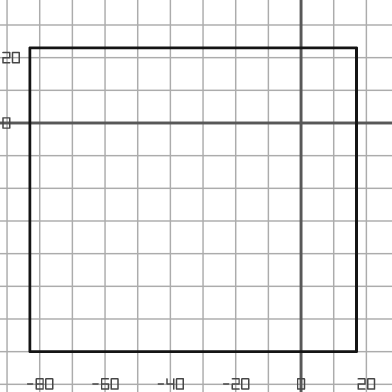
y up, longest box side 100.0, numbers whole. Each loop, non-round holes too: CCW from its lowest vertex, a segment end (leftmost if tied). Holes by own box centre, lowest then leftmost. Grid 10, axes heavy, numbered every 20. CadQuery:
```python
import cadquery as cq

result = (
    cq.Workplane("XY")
    .moveTo(-83.0, -70.0)
    .lineTo(17.0, -70.0)
    .lineTo(17.0, 23.0)
    .lineTo(-83.0, 23.0)
    .close()
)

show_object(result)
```